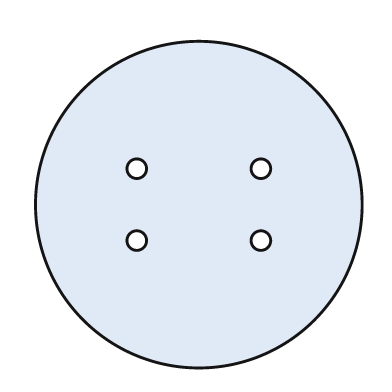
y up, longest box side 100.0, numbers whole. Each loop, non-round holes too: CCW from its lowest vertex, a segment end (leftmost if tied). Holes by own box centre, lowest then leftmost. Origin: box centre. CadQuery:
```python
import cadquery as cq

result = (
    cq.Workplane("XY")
    .moveTo(0.0, 0.0)
    .circle(50.0)
    .moveTo(-19.0, -11.0)
    .circle(3.0)
    .moveTo(19.0, -11.0)
    .circle(3.0)
    .moveTo(-19.0, 11.0)
    .circle(3.0)
    .moveTo(19.0, 11.0)
    .circle(3.0)
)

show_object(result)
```